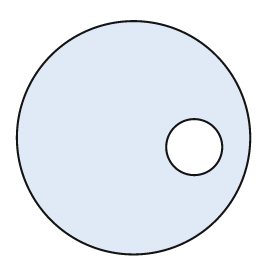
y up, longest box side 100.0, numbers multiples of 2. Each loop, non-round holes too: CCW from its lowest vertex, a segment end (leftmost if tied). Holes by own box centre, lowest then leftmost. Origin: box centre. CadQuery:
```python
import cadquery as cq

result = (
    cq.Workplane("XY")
    .moveTo(0.0, 0.0)
    .circle(50.0)
    .moveTo(26.0, -4.0)
    .circle(12.0)
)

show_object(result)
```